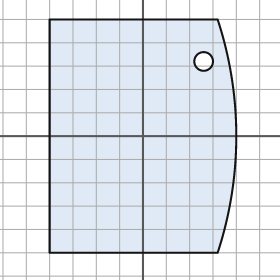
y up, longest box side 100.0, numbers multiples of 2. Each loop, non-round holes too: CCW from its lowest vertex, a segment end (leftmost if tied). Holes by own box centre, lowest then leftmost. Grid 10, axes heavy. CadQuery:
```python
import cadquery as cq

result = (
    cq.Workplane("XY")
    .moveTo(-40.0, -50.0)
    .lineTo(32.0, -50.0)
    .threePointArc((40.0, 0.0), (32.0, 50.0))
    .lineTo(-40.0, 50.0)
    .close()
    .moveTo(26.0, 32.0)
    .circle(4.0)
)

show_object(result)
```